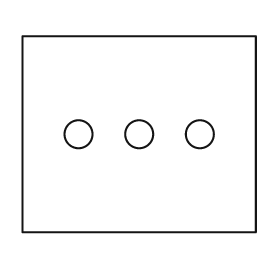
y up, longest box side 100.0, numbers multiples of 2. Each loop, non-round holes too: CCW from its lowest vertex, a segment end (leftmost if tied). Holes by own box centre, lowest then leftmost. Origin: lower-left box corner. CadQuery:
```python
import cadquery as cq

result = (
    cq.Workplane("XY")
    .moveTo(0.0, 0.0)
    .lineTo(100.0, 0.0)
    .lineTo(100.0, 84.0)
    .lineTo(0.0, 84.0)
    .close()
    .moveTo(24.0, 42.0)
    .circle(6.0)
    .moveTo(50.0, 42.0)
    .circle(6.0)
    .moveTo(76.0, 42.0)
    .circle(6.0)
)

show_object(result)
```